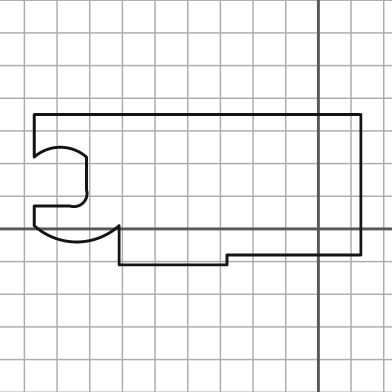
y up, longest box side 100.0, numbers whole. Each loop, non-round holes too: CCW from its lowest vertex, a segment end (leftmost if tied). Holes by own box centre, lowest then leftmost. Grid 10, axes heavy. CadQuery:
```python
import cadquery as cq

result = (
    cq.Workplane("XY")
    .moveTo(-61.0, -11.0)
    .lineTo(-28.0, -11.0)
    .lineTo(-28.0, -8.0)
    .lineTo(13.0, -8.0)
    .lineTo(13.0, 35.0)
    .lineTo(-87.0, 35.0)
    .lineTo(-87.0, 22.0)
    .threePointArc((-79.0, 25.0), (-71.0, 22.0))
    .lineTo(-71.0, 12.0)
    .threePointArc((-72.0, 8.0), (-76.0, 7.0))
    .lineTo(-87.0, 7.0)
    .lineTo(-87.0, 1.0)
    .threePointArc((-74.0, -4.0), (-61.0, 1.0))
    .close()
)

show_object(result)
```